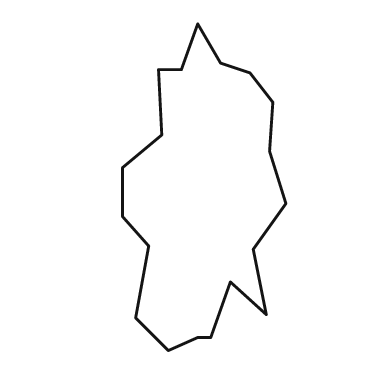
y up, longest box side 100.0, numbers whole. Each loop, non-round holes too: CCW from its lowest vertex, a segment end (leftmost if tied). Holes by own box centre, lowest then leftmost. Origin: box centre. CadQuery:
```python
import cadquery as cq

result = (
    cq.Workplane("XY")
    .moveTo(-11.0, -50.0)
    .lineTo(-2.0, -46.0)
    .lineTo(2.0, -46.0)
    .lineTo(8.0, -29.0)
    .lineTo(19.0, -39.0)
    .lineTo(15.0, -19.0)
    .lineTo(25.0, -5.0)
    .lineTo(20.0, 11.0)
    .lineTo(21.0, 26.0)
    .lineTo(14.0, 35.0)
    .lineTo(5.0, 38.0)
    .lineTo(-2.0, 50.0)
    .lineTo(-7.0, 36.0)
    .lineTo(-14.0, 36.0)
    .lineTo(-13.0, 16.0)
    .lineTo(-25.0, 6.0)
    .lineTo(-25.0, -9.0)
    .lineTo(-17.0, -18.0)
    .lineTo(-21.0, -40.0)
    .close()
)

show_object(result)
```